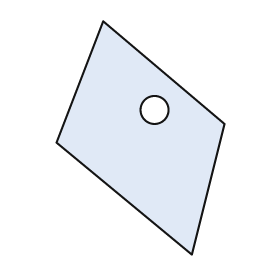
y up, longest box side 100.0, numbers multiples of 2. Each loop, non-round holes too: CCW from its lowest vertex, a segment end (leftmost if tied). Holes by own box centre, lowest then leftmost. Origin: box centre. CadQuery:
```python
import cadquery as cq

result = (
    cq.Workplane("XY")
    .moveTo(22.0, -50.0)
    .lineTo(36.0, 6.0)
    .lineTo(-16.0, 50.0)
    .lineTo(-36.0, -2.0)
    .close()
    .moveTo(6.0, 12.0)
    .circle(6.0)
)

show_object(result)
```